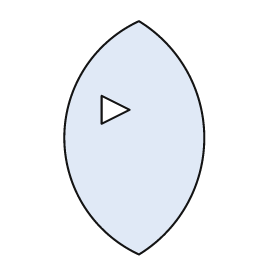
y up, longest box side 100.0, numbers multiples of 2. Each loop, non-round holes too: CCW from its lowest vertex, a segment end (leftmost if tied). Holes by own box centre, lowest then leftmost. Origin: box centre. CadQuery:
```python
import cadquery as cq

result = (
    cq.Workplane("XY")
    .moveTo(2.0, -50.0)
    .threePointArc((30.0, 0.0), (2.0, 50.0))
    .threePointArc((-30.0, 0.0), (2.0, -50.0))
    .close()
    .moveTo(-14.0, 6.0)
    .lineTo(-2.0, 12.0)
    .lineTo(-14.0, 18.0)
    .close()
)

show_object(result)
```